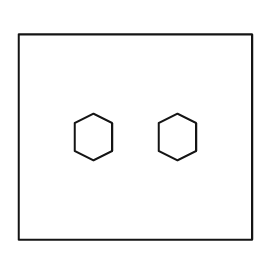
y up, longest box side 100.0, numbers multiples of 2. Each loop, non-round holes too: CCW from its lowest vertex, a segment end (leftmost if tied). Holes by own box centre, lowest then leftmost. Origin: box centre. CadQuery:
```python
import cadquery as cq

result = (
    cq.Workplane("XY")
    .moveTo(-50.0, -44.0)
    .lineTo(50.0, -44.0)
    .lineTo(50.0, 44.0)
    .lineTo(-50.0, 44.0)
    .close()
    .moveTo(-18.0, -10.0)
    .lineTo(-10.0, -6.0)
    .lineTo(-10.0, 6.0)
    .lineTo(-18.0, 10.0)
    .lineTo(-26.0, 6.0)
    .lineTo(-26.0, -6.0)
    .close()
    .moveTo(18.0, -10.0)
    .lineTo(26.0, -6.0)
    .lineTo(26.0, 6.0)
    .lineTo(18.0, 10.0)
    .lineTo(10.0, 6.0)
    .lineTo(10.0, -6.0)
    .close()
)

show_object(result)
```